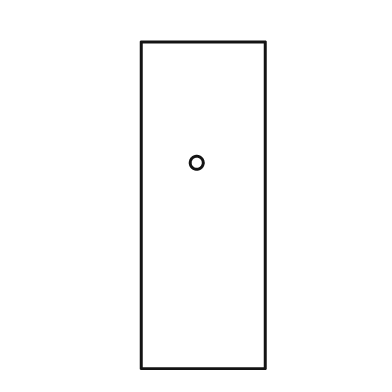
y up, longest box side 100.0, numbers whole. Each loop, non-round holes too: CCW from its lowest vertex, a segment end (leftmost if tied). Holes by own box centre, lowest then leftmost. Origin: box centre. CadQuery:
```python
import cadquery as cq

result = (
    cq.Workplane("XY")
    .moveTo(-19.0, -50.0)
    .lineTo(19.0, -50.0)
    .lineTo(19.0, 50.0)
    .lineTo(-19.0, 50.0)
    .close()
    .moveTo(-2.0, 13.0)
    .circle(2.0)
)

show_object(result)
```